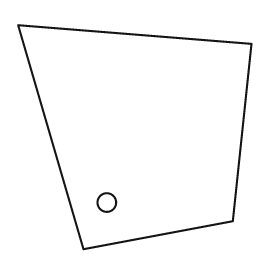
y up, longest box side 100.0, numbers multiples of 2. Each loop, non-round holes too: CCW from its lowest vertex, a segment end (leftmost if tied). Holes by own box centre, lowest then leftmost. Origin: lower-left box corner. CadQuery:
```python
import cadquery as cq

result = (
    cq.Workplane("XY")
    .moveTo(28.0, 0.0)
    .lineTo(92.0, 12.0)
    .lineTo(100.0, 88.0)
    .lineTo(0.0, 96.0)
    .close()
    .moveTo(38.0, 20.0)
    .circle(4.0)
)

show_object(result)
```